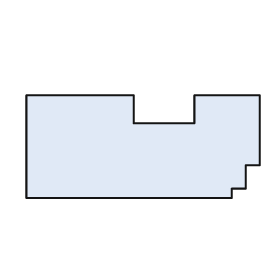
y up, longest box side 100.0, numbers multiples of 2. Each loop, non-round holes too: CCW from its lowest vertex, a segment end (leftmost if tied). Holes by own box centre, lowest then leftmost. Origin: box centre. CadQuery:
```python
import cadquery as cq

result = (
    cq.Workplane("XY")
    .moveTo(-50.0, -22.0)
    .lineTo(38.0, -22.0)
    .lineTo(38.0, -18.0)
    .lineTo(44.0, -18.0)
    .lineTo(44.0, -8.0)
    .lineTo(50.0, -8.0)
    .lineTo(50.0, 22.0)
    .lineTo(22.0, 22.0)
    .lineTo(22.0, 10.0)
    .lineTo(-4.0, 10.0)
    .lineTo(-4.0, 22.0)
    .lineTo(-50.0, 22.0)
    .close()
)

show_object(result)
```